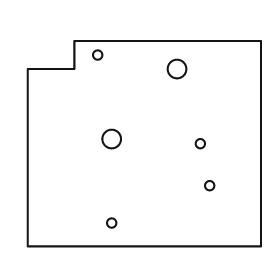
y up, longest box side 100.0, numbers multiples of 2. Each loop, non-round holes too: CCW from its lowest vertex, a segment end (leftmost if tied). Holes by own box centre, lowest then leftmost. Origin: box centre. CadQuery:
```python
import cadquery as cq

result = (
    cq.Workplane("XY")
    .moveTo(-50.0, -44.0)
    .lineTo(50.0, -44.0)
    .lineTo(50.0, 44.0)
    .lineTo(-30.0, 44.0)
    .lineTo(-30.0, 32.0)
    .lineTo(-50.0, 32.0)
    .close()
    .moveTo(-14.0, -34.0)
    .circle(2.0)
    .moveTo(28.0, -18.0)
    .circle(2.0)
    .moveTo(24.0, 0.0)
    .circle(2.0)
    .moveTo(-14.0, 2.0)
    .circle(4.0)
    .moveTo(14.0, 32.0)
    .circle(4.0)
    .moveTo(-20.0, 38.0)
    .circle(2.0)
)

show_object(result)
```